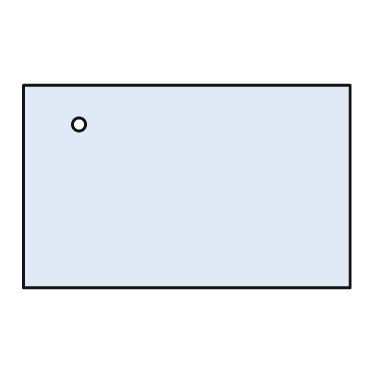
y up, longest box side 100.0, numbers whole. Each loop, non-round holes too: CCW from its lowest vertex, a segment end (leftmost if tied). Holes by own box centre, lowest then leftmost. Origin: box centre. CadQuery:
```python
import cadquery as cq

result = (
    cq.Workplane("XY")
    .moveTo(-50.0, -31.0)
    .lineTo(50.0, -31.0)
    .lineTo(50.0, 31.0)
    .lineTo(-50.0, 31.0)
    .close()
    .moveTo(-33.0, 19.0)
    .circle(2.0)
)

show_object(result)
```